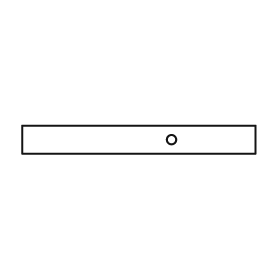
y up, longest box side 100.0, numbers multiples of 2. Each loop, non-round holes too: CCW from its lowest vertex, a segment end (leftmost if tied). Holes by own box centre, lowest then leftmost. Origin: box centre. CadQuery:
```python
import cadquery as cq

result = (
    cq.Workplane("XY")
    .moveTo(-50.0, -6.0)
    .lineTo(50.0, -6.0)
    .lineTo(50.0, 6.0)
    .lineTo(-50.0, 6.0)
    .close()
    .moveTo(14.0, 0.0)
    .circle(2.0)
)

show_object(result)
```